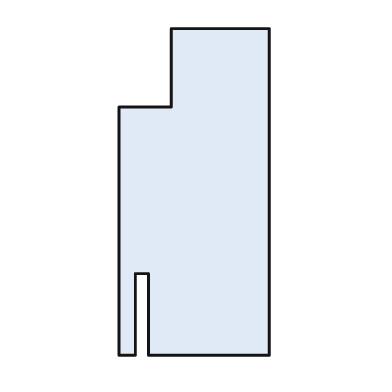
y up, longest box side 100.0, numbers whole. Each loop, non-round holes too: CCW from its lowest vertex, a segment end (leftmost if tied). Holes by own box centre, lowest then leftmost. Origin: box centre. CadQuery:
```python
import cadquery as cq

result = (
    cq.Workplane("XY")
    .moveTo(-23.0, -50.0)
    .lineTo(-18.0, -50.0)
    .lineTo(-18.0, -25.0)
    .lineTo(-14.0, -25.0)
    .lineTo(-14.0, -50.0)
    .lineTo(23.0, -50.0)
    .lineTo(23.0, 50.0)
    .lineTo(-7.0, 50.0)
    .lineTo(-7.0, 26.0)
    .lineTo(-23.0, 26.0)
    .close()
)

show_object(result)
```